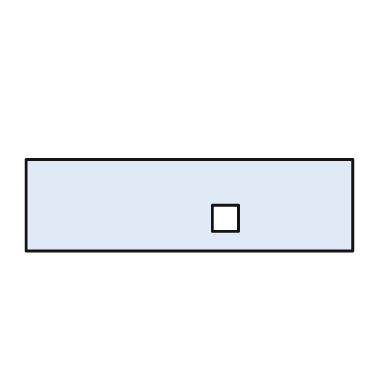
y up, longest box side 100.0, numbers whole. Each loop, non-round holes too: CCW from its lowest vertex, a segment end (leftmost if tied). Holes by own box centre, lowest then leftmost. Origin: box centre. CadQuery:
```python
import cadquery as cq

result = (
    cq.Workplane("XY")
    .moveTo(-50.0, -14.0)
    .lineTo(50.0, -14.0)
    .lineTo(50.0, 14.0)
    .lineTo(-50.0, 14.0)
    .close()
    .moveTo(7.0, -8.0)
    .lineTo(15.0, -8.0)
    .lineTo(15.0, 0.0)
    .lineTo(7.0, 0.0)
    .close()
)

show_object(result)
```